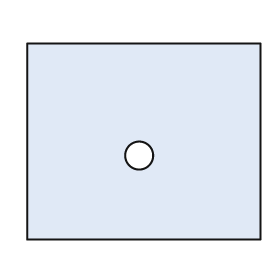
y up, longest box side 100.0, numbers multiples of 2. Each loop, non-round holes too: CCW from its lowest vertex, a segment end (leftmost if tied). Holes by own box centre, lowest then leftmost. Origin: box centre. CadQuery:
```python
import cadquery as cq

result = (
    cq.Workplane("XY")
    .moveTo(-50.0, -42.0)
    .lineTo(50.0, -42.0)
    .lineTo(50.0, 42.0)
    .lineTo(-50.0, 42.0)
    .close()
    .moveTo(-2.0, -6.0)
    .circle(6.0)
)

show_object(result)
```